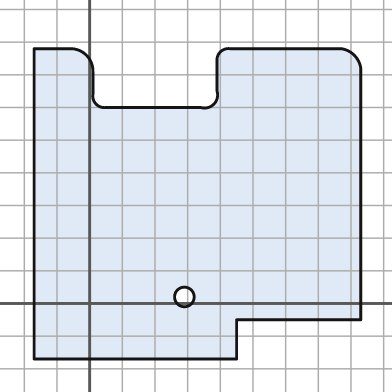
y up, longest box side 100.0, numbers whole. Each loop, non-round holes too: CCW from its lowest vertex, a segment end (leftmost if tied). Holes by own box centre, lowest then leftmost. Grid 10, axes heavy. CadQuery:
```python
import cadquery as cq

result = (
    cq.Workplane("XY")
    .moveTo(-17.0, -17.0)
    .lineTo(45.0, -17.0)
    .lineTo(45.0, -5.0)
    .lineTo(83.0, -5.0)
    .lineTo(83.0, 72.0)
    .threePointArc((81.0, 76.0), (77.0, 78.0))
    .lineTo(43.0, 78.0)
    .threePointArc((40.0, 77.0), (39.0, 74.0))
    .lineTo(39.0, 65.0)
    .threePointArc((38.0, 61.0), (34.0, 60.0))
    .lineTo(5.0, 60.0)
    .threePointArc((2.0, 61.0), (1.0, 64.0))
    .lineTo(1.0, 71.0)
    .threePointArc((-1.0, 76.0), (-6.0, 78.0))
    .lineTo(-17.0, 78.0)
    .close()
    .moveTo(29.0, 2.0)
    .circle(3.0)
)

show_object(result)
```